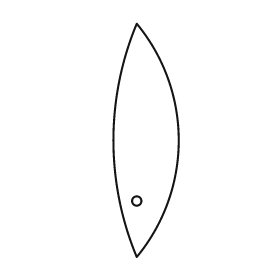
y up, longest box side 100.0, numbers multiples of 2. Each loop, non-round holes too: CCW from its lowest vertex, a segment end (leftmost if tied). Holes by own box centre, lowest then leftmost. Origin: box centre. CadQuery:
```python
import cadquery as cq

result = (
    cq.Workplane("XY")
    .moveTo(-4.0, -50.0)
    .threePointArc((14.0, 0.0), (-4.0, 50.0))
    .threePointArc((-14.0, 0.0), (-4.0, -50.0))
    .close()
    .moveTo(-4.0, -26.0)
    .circle(2.0)
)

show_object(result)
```